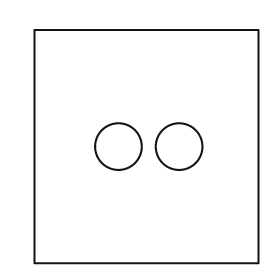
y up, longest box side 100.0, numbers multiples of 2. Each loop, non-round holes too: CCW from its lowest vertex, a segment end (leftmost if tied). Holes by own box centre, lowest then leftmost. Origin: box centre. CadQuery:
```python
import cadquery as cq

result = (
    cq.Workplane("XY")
    .moveTo(-48.0, -50.0)
    .lineTo(48.0, -50.0)
    .lineTo(48.0, 50.0)
    .lineTo(-48.0, 50.0)
    .close()
    .moveTo(-12.0, 0.0)
    .circle(10.0)
    .moveTo(14.0, 0.0)
    .circle(10.0)
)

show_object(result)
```